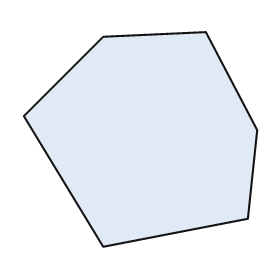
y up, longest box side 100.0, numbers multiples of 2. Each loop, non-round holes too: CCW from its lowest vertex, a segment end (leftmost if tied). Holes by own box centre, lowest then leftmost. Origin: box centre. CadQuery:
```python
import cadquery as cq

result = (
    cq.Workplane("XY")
    .moveTo(-16.0, -46.0)
    .lineTo(46.0, -34.0)
    .lineTo(50.0, 4.0)
    .lineTo(28.0, 46.0)
    .lineTo(-16.0, 44.0)
    .lineTo(-50.0, 10.0)
    .close()
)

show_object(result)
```